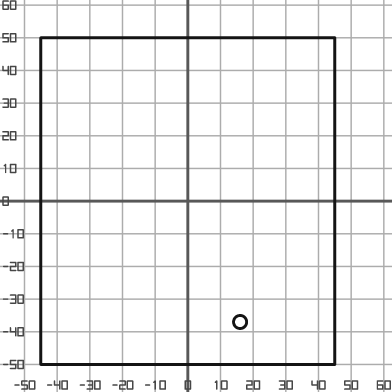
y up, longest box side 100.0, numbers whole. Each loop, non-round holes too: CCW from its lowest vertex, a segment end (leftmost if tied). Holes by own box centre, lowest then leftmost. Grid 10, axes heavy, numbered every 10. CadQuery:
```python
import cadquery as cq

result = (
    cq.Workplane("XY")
    .moveTo(-45.0, -50.0)
    .lineTo(45.0, -50.0)
    .lineTo(45.0, 50.0)
    .lineTo(-45.0, 50.0)
    .close()
    .moveTo(16.0, -37.0)
    .circle(2.0)
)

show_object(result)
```